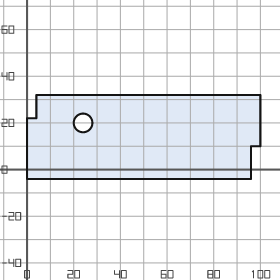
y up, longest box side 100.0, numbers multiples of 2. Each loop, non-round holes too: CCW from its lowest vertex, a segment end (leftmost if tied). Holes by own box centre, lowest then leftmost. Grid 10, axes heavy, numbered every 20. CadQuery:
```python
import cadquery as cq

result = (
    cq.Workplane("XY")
    .moveTo(0.0, -4.0)
    .lineTo(96.0, -4.0)
    .lineTo(96.0, 10.0)
    .lineTo(100.0, 10.0)
    .lineTo(100.0, 32.0)
    .lineTo(4.0, 32.0)
    .lineTo(4.0, 22.0)
    .lineTo(0.0, 22.0)
    .close()
    .moveTo(24.0, 20.0)
    .circle(4.0)
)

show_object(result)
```